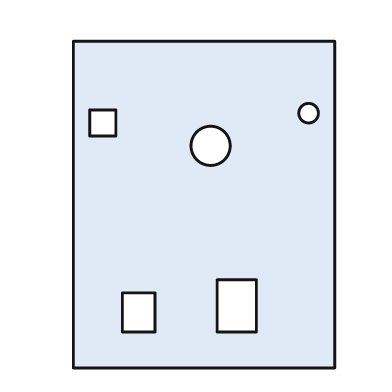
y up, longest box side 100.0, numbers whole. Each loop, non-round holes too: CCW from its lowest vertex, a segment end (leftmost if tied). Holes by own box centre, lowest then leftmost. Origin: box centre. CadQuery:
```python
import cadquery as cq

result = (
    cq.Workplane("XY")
    .moveTo(-40.0, -50.0)
    .lineTo(40.0, -50.0)
    .lineTo(40.0, 50.0)
    .lineTo(-40.0, 50.0)
    .close()
    .moveTo(-25.0, -39.0)
    .lineTo(-15.0, -39.0)
    .lineTo(-15.0, -27.0)
    .lineTo(-25.0, -27.0)
    .close()
    .moveTo(4.0, -39.0)
    .lineTo(16.0, -39.0)
    .lineTo(16.0, -23.0)
    .lineTo(4.0, -23.0)
    .close()
    .moveTo(2.0, 18.0)
    .circle(6.0)
    .moveTo(-35.0, 21.0)
    .lineTo(-27.0, 21.0)
    .lineTo(-27.0, 29.0)
    .lineTo(-35.0, 29.0)
    .close()
    .moveTo(32.0, 28.0)
    .circle(3.0)
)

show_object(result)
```